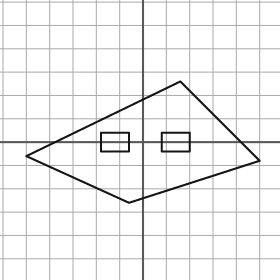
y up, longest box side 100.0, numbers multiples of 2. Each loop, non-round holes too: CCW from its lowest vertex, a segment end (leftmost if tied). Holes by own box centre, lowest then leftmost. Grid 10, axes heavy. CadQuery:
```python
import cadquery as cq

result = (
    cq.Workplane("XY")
    .moveTo(-6.0, -26.0)
    .lineTo(50.0, -8.0)
    .lineTo(16.0, 26.0)
    .lineTo(-50.0, -6.0)
    .close()
    .moveTo(-18.0, -4.0)
    .lineTo(-6.0, -4.0)
    .lineTo(-6.0, 4.0)
    .lineTo(-18.0, 4.0)
    .close()
    .moveTo(8.0, -4.0)
    .lineTo(20.0, -4.0)
    .lineTo(20.0, 4.0)
    .lineTo(8.0, 4.0)
    .close()
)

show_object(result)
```